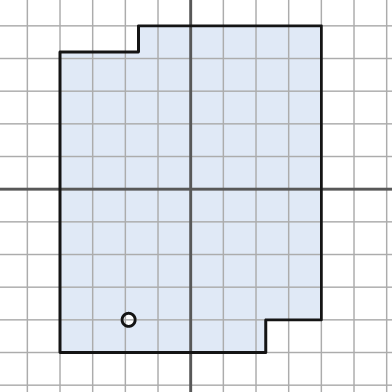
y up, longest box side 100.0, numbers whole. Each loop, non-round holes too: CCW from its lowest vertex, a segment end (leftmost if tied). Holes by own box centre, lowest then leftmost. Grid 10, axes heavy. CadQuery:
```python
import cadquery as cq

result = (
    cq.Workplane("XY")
    .moveTo(-40.0, -50.0)
    .lineTo(23.0, -50.0)
    .lineTo(23.0, -40.0)
    .lineTo(40.0, -40.0)
    .lineTo(40.0, 50.0)
    .lineTo(-16.0, 50.0)
    .lineTo(-16.0, 42.0)
    .lineTo(-40.0, 42.0)
    .close()
    .moveTo(-19.0, -40.0)
    .circle(2.0)
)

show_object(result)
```